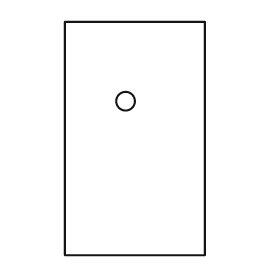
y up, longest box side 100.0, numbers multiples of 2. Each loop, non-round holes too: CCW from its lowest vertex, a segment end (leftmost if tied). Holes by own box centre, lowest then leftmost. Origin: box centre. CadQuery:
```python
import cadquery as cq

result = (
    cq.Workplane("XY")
    .moveTo(-30.0, -50.0)
    .lineTo(30.0, -50.0)
    .lineTo(30.0, 50.0)
    .lineTo(-30.0, 50.0)
    .close()
    .moveTo(-4.0, 16.0)
    .circle(4.0)
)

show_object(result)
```